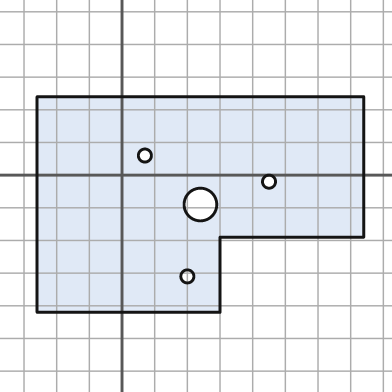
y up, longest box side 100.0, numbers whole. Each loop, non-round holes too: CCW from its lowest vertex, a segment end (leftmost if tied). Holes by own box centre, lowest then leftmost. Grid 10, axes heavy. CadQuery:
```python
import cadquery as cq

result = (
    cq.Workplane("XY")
    .moveTo(-26.0, -42.0)
    .lineTo(30.0, -42.0)
    .lineTo(30.0, -19.0)
    .lineTo(74.0, -19.0)
    .lineTo(74.0, 24.0)
    .lineTo(-26.0, 24.0)
    .close()
    .moveTo(20.0, -31.0)
    .circle(2.0)
    .moveTo(24.0, -9.0)
    .circle(5.0)
    .moveTo(45.0, -2.0)
    .circle(2.0)
    .moveTo(7.0, 6.0)
    .circle(2.0)
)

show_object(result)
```